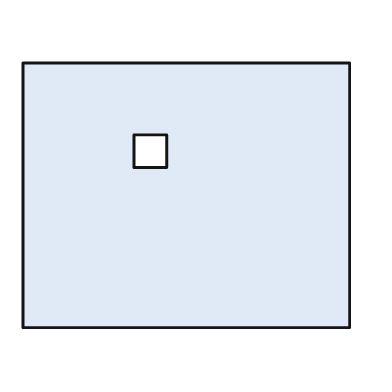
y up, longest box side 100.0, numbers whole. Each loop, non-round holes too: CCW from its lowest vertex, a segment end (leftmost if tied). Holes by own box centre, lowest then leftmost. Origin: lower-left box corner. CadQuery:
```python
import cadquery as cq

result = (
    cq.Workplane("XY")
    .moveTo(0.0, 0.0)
    .lineTo(100.0, 0.0)
    .lineTo(100.0, 81.0)
    .lineTo(0.0, 81.0)
    .close()
    .moveTo(34.0, 49.0)
    .lineTo(44.0, 49.0)
    .lineTo(44.0, 59.0)
    .lineTo(34.0, 59.0)
    .close()
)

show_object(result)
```